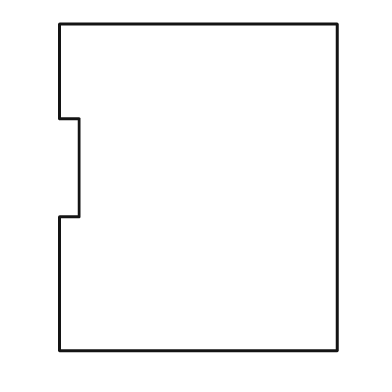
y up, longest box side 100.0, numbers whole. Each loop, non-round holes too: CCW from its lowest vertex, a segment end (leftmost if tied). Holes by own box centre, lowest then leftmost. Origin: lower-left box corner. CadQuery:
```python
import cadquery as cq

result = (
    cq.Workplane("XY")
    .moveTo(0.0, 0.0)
    .lineTo(85.0, 0.0)
    .lineTo(85.0, 100.0)
    .lineTo(0.0, 100.0)
    .lineTo(0.0, 71.0)
    .lineTo(6.0, 71.0)
    .lineTo(6.0, 41.0)
    .lineTo(0.0, 41.0)
    .close()
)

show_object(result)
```